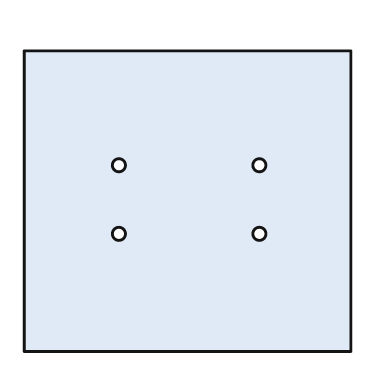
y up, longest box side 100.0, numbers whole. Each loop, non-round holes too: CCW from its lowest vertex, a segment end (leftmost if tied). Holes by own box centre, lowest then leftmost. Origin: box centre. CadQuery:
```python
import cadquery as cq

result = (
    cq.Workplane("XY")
    .moveTo(-50.0, -46.0)
    .lineTo(50.0, -46.0)
    .lineTo(50.0, 46.0)
    .lineTo(-50.0, 46.0)
    .close()
    .moveTo(-21.0, -10.0)
    .circle(2.0)
    .moveTo(22.0, -10.0)
    .circle(2.0)
    .moveTo(-21.0, 11.0)
    .circle(2.0)
    .moveTo(22.0, 11.0)
    .circle(2.0)
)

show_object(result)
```